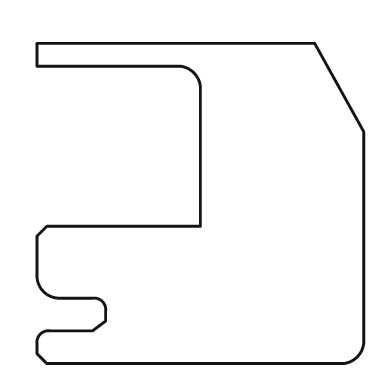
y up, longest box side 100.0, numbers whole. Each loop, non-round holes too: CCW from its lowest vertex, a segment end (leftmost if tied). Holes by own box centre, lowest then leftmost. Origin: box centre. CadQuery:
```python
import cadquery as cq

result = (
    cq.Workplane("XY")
    .moveTo(-47.0, -49.0)
    .lineTo(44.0, -49.0)
    .threePointArc((48.0, -47.0), (50.0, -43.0))
    .lineTo(50.0, 22.0)
    .lineTo(35.0, 49.0)
    .lineTo(-50.0, 49.0)
    .lineTo(-50.0, 42.0)
    .lineTo(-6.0, 42.0)
    .threePointArc((-2.0, 40.0), (0.0, 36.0))
    .lineTo(0.0, -7.0)
    .lineTo(-47.0, -7.0)
    .lineTo(-50.0, -10.0)
    .lineTo(-50.0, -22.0)
    .threePointArc((-48.0, -27.0), (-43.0, -29.0))
    .lineTo(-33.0, -29.0)
    .threePointArc((-30.0, -30.0), (-29.0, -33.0))
    .lineTo(-29.0, -36.0)
    .lineTo(-33.0, -39.0)
    .lineTo(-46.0, -39.0)
    .threePointArc((-49.0, -40.0), (-50.0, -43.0))
    .lineTo(-50.0, -46.0)
    .close()
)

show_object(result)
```